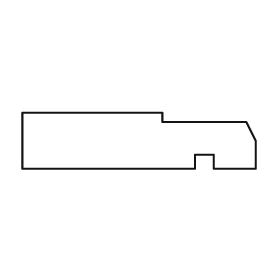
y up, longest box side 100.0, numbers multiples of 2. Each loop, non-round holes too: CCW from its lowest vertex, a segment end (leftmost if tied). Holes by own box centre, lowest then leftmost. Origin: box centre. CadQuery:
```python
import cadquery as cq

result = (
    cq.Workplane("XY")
    .moveTo(-50.0, -12.0)
    .lineTo(24.0, -12.0)
    .lineTo(24.0, -6.0)
    .lineTo(32.0, -6.0)
    .lineTo(32.0, -12.0)
    .lineTo(50.0, -12.0)
    .lineTo(50.0, 0.0)
    .lineTo(46.0, 8.0)
    .lineTo(10.0, 8.0)
    .lineTo(10.0, 12.0)
    .lineTo(-50.0, 12.0)
    .close()
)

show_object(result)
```